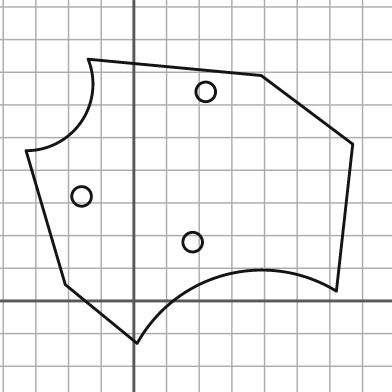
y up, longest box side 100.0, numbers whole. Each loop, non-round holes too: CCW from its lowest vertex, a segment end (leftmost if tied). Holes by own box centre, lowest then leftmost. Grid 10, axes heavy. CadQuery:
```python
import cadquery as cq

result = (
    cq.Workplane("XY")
    .moveTo(1.0, -13.0)
    .threePointArc((28.0, 8.0), (62.0, 3.0))
    .lineTo(67.0, 48.0)
    .lineTo(39.0, 69.0)
    .lineTo(-14.0, 74.0)
    .threePointArc((-16.0, 55.0), (-33.0, 46.0))
    .lineTo(-21.0, 5.0)
    .close()
    .moveTo(18.0, 18.0)
    .circle(3.0)
    .moveTo(-16.0, 32.0)
    .circle(3.0)
    .moveTo(22.0, 64.0)
    .circle(3.0)
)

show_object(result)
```